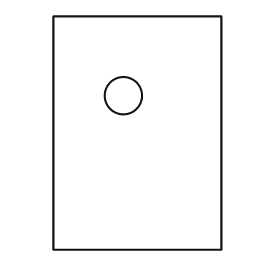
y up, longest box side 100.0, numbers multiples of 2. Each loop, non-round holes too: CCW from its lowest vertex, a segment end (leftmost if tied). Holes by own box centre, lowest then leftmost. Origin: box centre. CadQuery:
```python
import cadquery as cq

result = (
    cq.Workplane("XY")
    .moveTo(-36.0, -50.0)
    .lineTo(36.0, -50.0)
    .lineTo(36.0, 50.0)
    .lineTo(-36.0, 50.0)
    .close()
    .moveTo(-6.0, 16.0)
    .circle(8.0)
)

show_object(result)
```